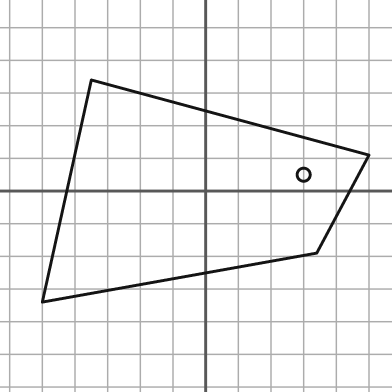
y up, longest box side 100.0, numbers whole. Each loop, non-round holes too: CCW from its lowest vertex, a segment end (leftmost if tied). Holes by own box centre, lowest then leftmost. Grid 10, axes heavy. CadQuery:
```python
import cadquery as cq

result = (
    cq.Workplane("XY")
    .moveTo(-50.0, -34.0)
    .lineTo(34.0, -19.0)
    .lineTo(50.0, 11.0)
    .lineTo(-35.0, 34.0)
    .close()
    .moveTo(30.0, 5.0)
    .circle(2.0)
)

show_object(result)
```